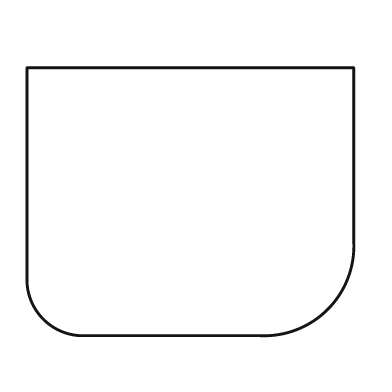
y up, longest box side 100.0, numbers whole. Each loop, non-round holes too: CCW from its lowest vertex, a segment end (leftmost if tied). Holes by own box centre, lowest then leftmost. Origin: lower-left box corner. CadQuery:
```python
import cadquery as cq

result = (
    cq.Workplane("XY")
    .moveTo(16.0, 0.0)
    .lineTo(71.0, 0.0)
    .threePointArc((92.0, 8.0), (100.0, 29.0))
    .lineTo(100.0, 82.0)
    .lineTo(0.0, 82.0)
    .lineTo(0.0, 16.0)
    .threePointArc((5.0, 5.0), (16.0, 0.0))
    .close()
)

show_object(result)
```